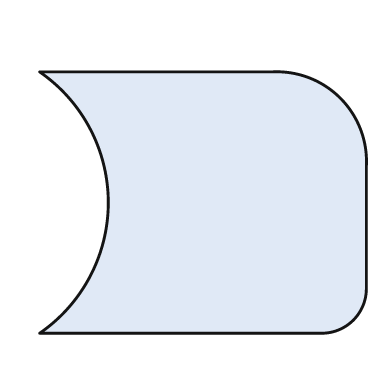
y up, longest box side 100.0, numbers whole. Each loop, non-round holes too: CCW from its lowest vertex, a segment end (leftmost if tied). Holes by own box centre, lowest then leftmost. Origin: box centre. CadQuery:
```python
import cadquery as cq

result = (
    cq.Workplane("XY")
    .moveTo(-50.0, -40.0)
    .lineTo(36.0, -40.0)
    .threePointArc((46.0, -36.0), (50.0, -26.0))
    .lineTo(50.0, 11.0)
    .threePointArc((42.0, 32.0), (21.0, 40.0))
    .lineTo(-50.0, 40.0)
    .threePointArc((-29.0, 0.0), (-50.0, -40.0))
    .close()
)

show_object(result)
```